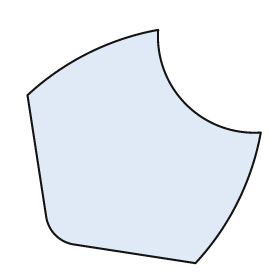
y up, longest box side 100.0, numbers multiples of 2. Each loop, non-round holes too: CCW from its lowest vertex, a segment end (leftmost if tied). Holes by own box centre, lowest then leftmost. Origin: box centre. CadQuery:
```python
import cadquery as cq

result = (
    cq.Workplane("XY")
    .moveTo(22.0, -50.0)
    .threePointArc((40.0, -24.0), (50.0, 6.0))
    .threePointArc((18.0, 18.0), (6.0, 50.0))
    .threePointArc((-24.0, 40.0), (-50.0, 22.0))
    .lineTo(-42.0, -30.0)
    .threePointArc((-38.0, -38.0), (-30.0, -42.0))
    .close()
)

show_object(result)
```